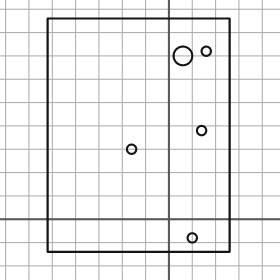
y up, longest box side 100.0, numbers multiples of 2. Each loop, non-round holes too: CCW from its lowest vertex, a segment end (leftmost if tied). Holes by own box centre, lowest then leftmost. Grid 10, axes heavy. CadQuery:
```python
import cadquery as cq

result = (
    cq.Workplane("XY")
    .moveTo(-52.0, -14.0)
    .lineTo(26.0, -14.0)
    .lineTo(26.0, 86.0)
    .lineTo(-52.0, 86.0)
    .close()
    .moveTo(10.0, -8.0)
    .circle(2.0)
    .moveTo(-16.0, 30.0)
    .circle(2.0)
    .moveTo(14.0, 38.0)
    .circle(2.0)
    .moveTo(6.0, 70.0)
    .circle(4.0)
    .moveTo(16.0, 72.0)
    .circle(2.0)
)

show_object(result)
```